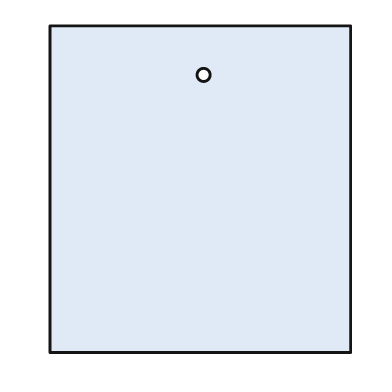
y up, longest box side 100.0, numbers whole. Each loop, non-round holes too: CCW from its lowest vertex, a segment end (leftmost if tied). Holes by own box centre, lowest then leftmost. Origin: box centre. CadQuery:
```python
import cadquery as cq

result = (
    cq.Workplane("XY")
    .moveTo(-46.0, -50.0)
    .lineTo(46.0, -50.0)
    .lineTo(46.0, 50.0)
    .lineTo(-46.0, 50.0)
    .close()
    .moveTo(1.0, 35.0)
    .circle(2.0)
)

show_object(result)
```